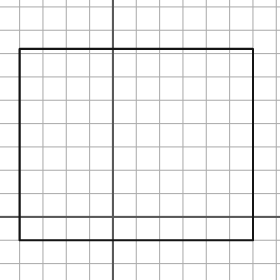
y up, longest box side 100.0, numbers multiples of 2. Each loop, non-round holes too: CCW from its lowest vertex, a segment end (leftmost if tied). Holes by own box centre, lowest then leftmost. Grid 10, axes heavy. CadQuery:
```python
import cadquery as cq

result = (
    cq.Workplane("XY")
    .moveTo(-40.0, -10.0)
    .lineTo(60.0, -10.0)
    .lineTo(60.0, 72.0)
    .lineTo(-40.0, 72.0)
    .close()
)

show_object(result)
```